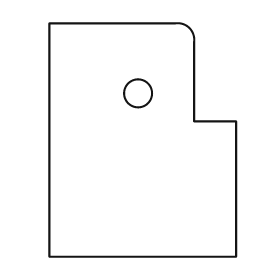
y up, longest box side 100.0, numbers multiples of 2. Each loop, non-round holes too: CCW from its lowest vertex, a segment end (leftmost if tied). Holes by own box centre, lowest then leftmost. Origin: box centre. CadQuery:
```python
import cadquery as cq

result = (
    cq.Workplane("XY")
    .moveTo(-40.0, -50.0)
    .lineTo(40.0, -50.0)
    .lineTo(40.0, 8.0)
    .lineTo(22.0, 8.0)
    .lineTo(22.0, 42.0)
    .threePointArc((20.0, 48.0), (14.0, 50.0))
    .lineTo(-40.0, 50.0)
    .close()
    .moveTo(-2.0, 20.0)
    .circle(6.0)
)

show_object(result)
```